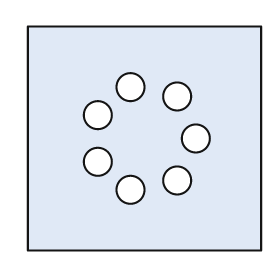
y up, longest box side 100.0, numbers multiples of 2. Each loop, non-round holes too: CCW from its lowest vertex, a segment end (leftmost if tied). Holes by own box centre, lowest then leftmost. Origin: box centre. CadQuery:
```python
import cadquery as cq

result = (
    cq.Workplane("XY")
    .moveTo(-50.0, -48.0)
    .lineTo(50.0, -48.0)
    .lineTo(50.0, 48.0)
    .lineTo(-50.0, 48.0)
    .close()
    .moveTo(-6.0, -22.0)
    .circle(6.0)
    .moveTo(14.0, -18.0)
    .circle(6.0)
    .moveTo(-20.0, -10.0)
    .circle(6.0)
    .moveTo(22.0, 0.0)
    .circle(6.0)
    .moveTo(-20.0, 10.0)
    .circle(6.0)
    .moveTo(14.0, 18.0)
    .circle(6.0)
    .moveTo(-6.0, 22.0)
    .circle(6.0)
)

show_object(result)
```